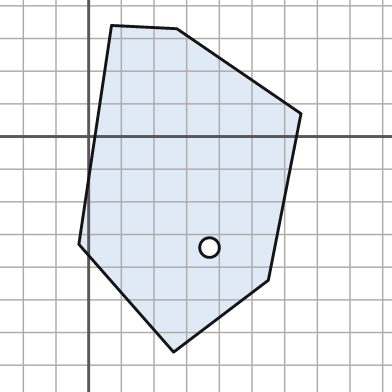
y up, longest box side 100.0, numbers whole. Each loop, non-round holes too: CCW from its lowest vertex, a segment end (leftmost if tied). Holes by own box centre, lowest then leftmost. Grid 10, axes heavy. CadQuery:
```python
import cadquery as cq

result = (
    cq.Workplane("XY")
    .moveTo(26.0, -66.0)
    .lineTo(55.0, -44.0)
    .lineTo(65.0, 7.0)
    .lineTo(27.0, 33.0)
    .lineTo(7.0, 34.0)
    .lineTo(-3.0, -33.0)
    .close()
    .moveTo(37.0, -34.0)
    .circle(3.0)
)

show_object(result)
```